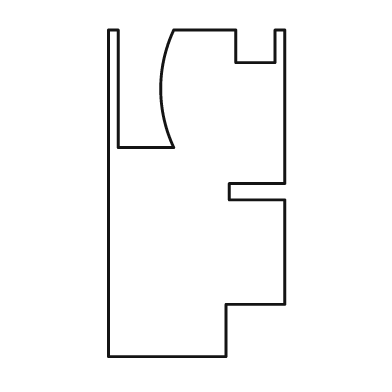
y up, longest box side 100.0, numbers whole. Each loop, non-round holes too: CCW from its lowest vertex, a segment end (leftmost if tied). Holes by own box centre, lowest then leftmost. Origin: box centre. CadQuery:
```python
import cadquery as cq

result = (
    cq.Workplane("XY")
    .moveTo(-27.0, -50.0)
    .lineTo(9.0, -50.0)
    .lineTo(9.0, -34.0)
    .lineTo(27.0, -34.0)
    .lineTo(27.0, -2.0)
    .lineTo(10.0, -2.0)
    .lineTo(10.0, 3.0)
    .lineTo(27.0, 3.0)
    .lineTo(27.0, 50.0)
    .lineTo(24.0, 50.0)
    .lineTo(24.0, 40.0)
    .lineTo(12.0, 40.0)
    .lineTo(12.0, 50.0)
    .lineTo(-7.0, 50.0)
    .threePointArc((-11.0, 32.0), (-7.0, 14.0))
    .lineTo(-24.0, 14.0)
    .lineTo(-24.0, 50.0)
    .lineTo(-27.0, 50.0)
    .close()
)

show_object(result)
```